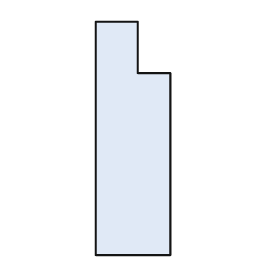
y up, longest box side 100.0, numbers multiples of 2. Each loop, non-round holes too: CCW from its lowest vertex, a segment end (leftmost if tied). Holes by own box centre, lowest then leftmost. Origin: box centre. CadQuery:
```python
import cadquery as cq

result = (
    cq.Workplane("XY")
    .moveTo(-16.0, -50.0)
    .lineTo(16.0, -50.0)
    .lineTo(16.0, 28.0)
    .lineTo(2.0, 28.0)
    .lineTo(2.0, 50.0)
    .lineTo(-16.0, 50.0)
    .close()
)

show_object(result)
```